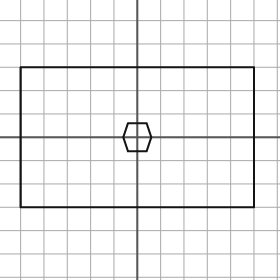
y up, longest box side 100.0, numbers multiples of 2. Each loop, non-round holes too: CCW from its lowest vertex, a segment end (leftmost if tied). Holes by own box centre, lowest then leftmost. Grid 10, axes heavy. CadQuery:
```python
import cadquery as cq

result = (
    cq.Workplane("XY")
    .moveTo(-50.0, -30.0)
    .lineTo(50.0, -30.0)
    .lineTo(50.0, 30.0)
    .lineTo(-50.0, 30.0)
    .close()
    .moveTo(-4.0, -6.0)
    .lineTo(4.0, -6.0)
    .lineTo(6.0, 0.0)
    .lineTo(4.0, 6.0)
    .lineTo(-4.0, 6.0)
    .lineTo(-6.0, 0.0)
    .close()
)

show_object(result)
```